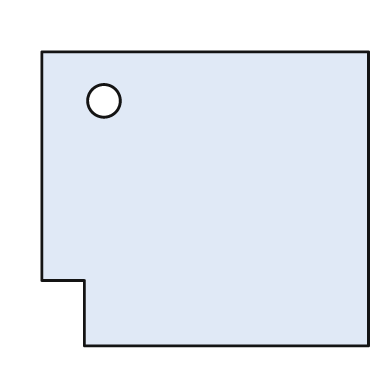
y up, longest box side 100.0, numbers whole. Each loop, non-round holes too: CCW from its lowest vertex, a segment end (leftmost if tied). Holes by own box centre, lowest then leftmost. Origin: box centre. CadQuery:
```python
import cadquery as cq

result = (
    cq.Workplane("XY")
    .moveTo(-37.0, -45.0)
    .lineTo(50.0, -45.0)
    .lineTo(50.0, 45.0)
    .lineTo(-50.0, 45.0)
    .lineTo(-50.0, -25.0)
    .lineTo(-37.0, -25.0)
    .close()
    .moveTo(-31.0, 30.0)
    .circle(5.0)
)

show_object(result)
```